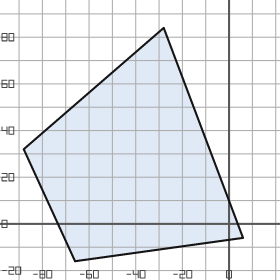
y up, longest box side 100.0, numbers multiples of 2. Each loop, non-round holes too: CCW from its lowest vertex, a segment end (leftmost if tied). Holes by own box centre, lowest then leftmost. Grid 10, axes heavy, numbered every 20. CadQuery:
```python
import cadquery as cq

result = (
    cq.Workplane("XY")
    .moveTo(-66.0, -16.0)
    .lineTo(6.0, -6.0)
    .lineTo(-28.0, 84.0)
    .lineTo(-88.0, 32.0)
    .close()
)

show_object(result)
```